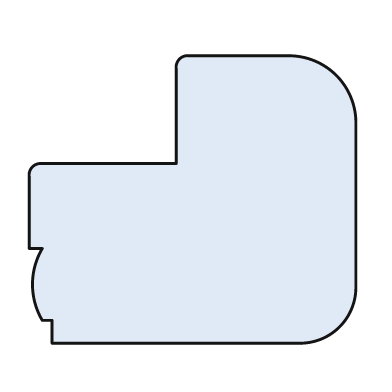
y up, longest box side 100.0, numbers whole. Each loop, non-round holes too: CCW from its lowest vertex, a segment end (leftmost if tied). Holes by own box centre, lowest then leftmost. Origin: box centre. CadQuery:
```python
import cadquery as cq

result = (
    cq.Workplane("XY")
    .moveTo(-43.0, -44.0)
    .lineTo(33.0, -44.0)
    .threePointArc((45.0, -39.0), (50.0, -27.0))
    .lineTo(50.0, 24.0)
    .threePointArc((44.0, 38.0), (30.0, 44.0))
    .lineTo(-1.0, 44.0)
    .threePointArc((-4.0, 43.0), (-5.0, 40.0))
    .lineTo(-5.0, 11.0)
    .lineTo(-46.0, 11.0)
    .threePointArc((-49.0, 10.0), (-50.0, 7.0))
    .lineTo(-50.0, -15.0)
    .lineTo(-46.0, -15.0)
    .threePointArc((-49.0, -26.0), (-46.0, -37.0))
    .lineTo(-43.0, -37.0)
    .close()
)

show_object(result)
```